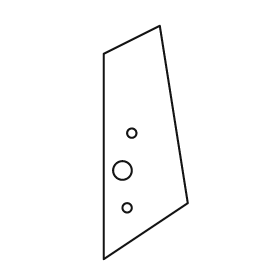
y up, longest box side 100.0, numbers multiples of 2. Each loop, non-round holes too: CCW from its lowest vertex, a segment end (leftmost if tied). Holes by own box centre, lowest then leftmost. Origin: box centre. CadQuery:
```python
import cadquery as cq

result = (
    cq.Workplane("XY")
    .moveTo(-18.0, -50.0)
    .lineTo(18.0, -26.0)
    .lineTo(6.0, 50.0)
    .lineTo(-18.0, 38.0)
    .close()
    .moveTo(-8.0, -28.0)
    .circle(2.0)
    .moveTo(-10.0, -12.0)
    .circle(4.0)
    .moveTo(-6.0, 4.0)
    .circle(2.0)
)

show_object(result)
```